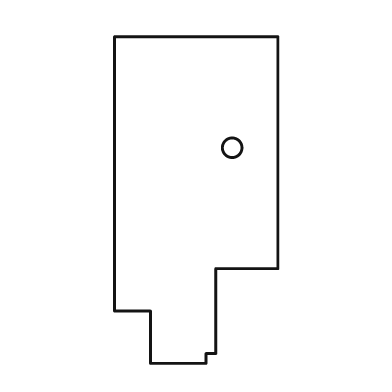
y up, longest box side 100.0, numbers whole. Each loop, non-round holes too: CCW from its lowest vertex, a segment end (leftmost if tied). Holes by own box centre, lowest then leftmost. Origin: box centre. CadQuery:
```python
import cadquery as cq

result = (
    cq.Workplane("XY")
    .moveTo(-14.0, -50.0)
    .lineTo(3.0, -50.0)
    .lineTo(3.0, -47.0)
    .lineTo(6.0, -47.0)
    .lineTo(6.0, -21.0)
    .lineTo(25.0, -21.0)
    .lineTo(25.0, 50.0)
    .lineTo(-25.0, 50.0)
    .lineTo(-25.0, -34.0)
    .lineTo(-14.0, -34.0)
    .close()
    .moveTo(11.0, 16.0)
    .circle(3.0)
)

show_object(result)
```